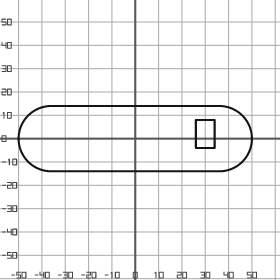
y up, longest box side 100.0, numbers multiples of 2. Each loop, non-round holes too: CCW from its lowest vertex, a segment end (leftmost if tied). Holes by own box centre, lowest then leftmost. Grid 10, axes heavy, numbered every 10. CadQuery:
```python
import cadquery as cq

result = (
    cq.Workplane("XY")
    .moveTo(-36.0, -14.0)
    .lineTo(36.0, -14.0)
    .threePointArc((50.0, 0.0), (36.0, 14.0))
    .lineTo(-36.0, 14.0)
    .threePointArc((-50.0, 0.0), (-36.0, -14.0))
    .close()
    .moveTo(26.0, -4.0)
    .lineTo(34.0, -4.0)
    .lineTo(34.0, 8.0)
    .lineTo(26.0, 8.0)
    .close()
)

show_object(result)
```